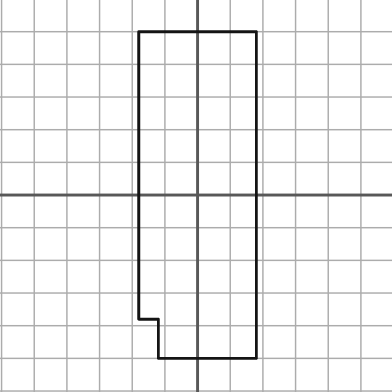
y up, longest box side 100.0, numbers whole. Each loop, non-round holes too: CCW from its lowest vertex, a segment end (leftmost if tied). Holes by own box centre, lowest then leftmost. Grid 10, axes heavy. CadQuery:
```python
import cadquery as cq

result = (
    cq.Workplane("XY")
    .moveTo(-12.0, -50.0)
    .lineTo(18.0, -50.0)
    .lineTo(18.0, 50.0)
    .lineTo(-18.0, 50.0)
    .lineTo(-18.0, -38.0)
    .lineTo(-12.0, -38.0)
    .close()
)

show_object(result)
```